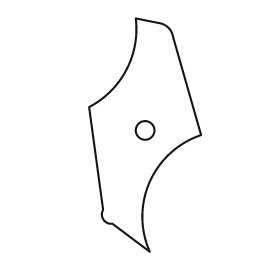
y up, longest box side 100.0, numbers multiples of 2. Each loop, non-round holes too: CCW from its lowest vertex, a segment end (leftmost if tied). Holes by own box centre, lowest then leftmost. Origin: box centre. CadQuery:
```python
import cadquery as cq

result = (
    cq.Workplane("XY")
    .moveTo(2.0, -50.0)
    .threePointArc((2.0, -20.0), (24.0, 0.0))
    .lineTo(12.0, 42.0)
    .threePointArc((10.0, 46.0), (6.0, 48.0))
    .lineTo(-4.0, 50.0)
    .threePointArc((-8.0, 28.0), (-24.0, 12.0))
    .lineTo(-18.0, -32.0)
    .threePointArc((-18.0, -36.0), (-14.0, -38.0))
    .close()
    .moveTo(0.0, 2.0)
    .circle(4.0)
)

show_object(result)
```